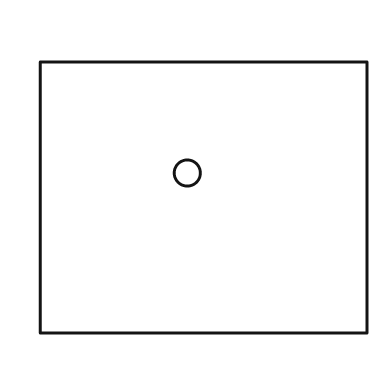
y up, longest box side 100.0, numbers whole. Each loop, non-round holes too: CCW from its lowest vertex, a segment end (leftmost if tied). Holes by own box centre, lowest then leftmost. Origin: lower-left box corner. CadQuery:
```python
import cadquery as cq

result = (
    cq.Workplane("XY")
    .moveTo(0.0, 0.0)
    .lineTo(100.0, 0.0)
    .lineTo(100.0, 83.0)
    .lineTo(0.0, 83.0)
    .close()
    .moveTo(45.0, 49.0)
    .circle(4.0)
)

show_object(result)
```